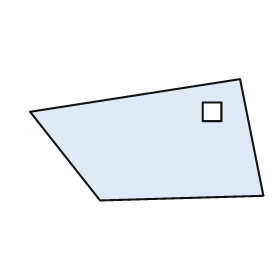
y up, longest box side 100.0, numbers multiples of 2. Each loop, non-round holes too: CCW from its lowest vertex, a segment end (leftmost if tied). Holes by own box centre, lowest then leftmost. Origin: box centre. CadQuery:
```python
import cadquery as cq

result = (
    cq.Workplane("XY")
    .moveTo(-20.0, -26.0)
    .lineTo(50.0, -24.0)
    .lineTo(40.0, 26.0)
    .lineTo(-50.0, 12.0)
    .close()
    .moveTo(24.0, 8.0)
    .lineTo(32.0, 8.0)
    .lineTo(32.0, 16.0)
    .lineTo(24.0, 16.0)
    .close()
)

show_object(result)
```